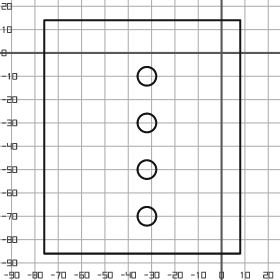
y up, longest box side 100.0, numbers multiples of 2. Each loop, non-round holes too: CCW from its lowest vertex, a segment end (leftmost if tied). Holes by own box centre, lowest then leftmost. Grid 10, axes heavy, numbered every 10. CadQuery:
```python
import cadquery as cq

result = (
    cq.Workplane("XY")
    .moveTo(-76.0, -86.0)
    .lineTo(8.0, -86.0)
    .lineTo(8.0, 14.0)
    .lineTo(-76.0, 14.0)
    .close()
    .moveTo(-32.0, -70.0)
    .circle(4.0)
    .moveTo(-32.0, -50.0)
    .circle(4.0)
    .moveTo(-32.0, -30.0)
    .circle(4.0)
    .moveTo(-32.0, -10.0)
    .circle(4.0)
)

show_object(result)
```